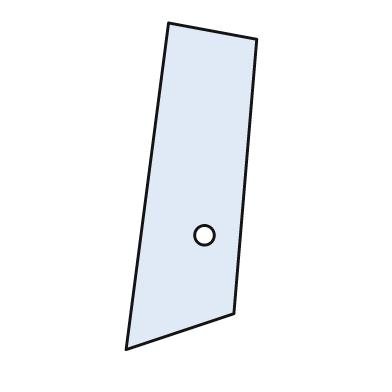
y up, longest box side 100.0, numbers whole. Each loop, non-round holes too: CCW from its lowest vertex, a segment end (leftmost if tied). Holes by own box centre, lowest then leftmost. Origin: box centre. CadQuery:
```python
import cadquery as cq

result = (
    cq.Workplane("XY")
    .moveTo(-20.0, -50.0)
    .lineTo(13.0, -39.0)
    .lineTo(20.0, 45.0)
    .lineTo(-7.0, 50.0)
    .close()
    .moveTo(4.0, -15.0)
    .circle(3.0)
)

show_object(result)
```